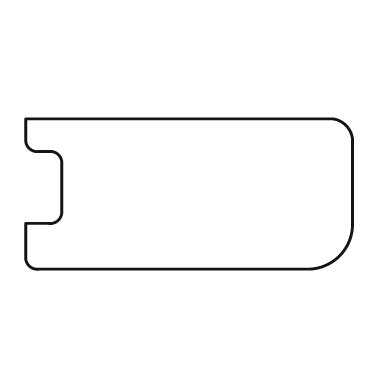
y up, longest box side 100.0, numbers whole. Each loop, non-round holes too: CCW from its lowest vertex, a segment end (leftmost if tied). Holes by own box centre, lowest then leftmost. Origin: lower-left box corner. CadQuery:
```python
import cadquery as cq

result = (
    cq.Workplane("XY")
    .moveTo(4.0, 0.0)
    .lineTo(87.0, 0.0)
    .threePointArc((96.0, 4.0), (100.0, 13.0))
    .lineTo(100.0, 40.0)
    .threePointArc((98.0, 44.0), (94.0, 46.0))
    .lineTo(0.0, 46.0)
    .lineTo(0.0, 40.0)
    .threePointArc((1.0, 37.0), (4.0, 36.0))
    .lineTo(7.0, 36.0)
    .threePointArc((10.0, 35.0), (11.0, 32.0))
    .lineTo(11.0, 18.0)
    .threePointArc((10.0, 15.0), (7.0, 14.0))
    .lineTo(0.0, 14.0)
    .lineTo(0.0, 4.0)
    .threePointArc((1.0, 1.0), (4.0, 0.0))
    .close()
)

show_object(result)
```